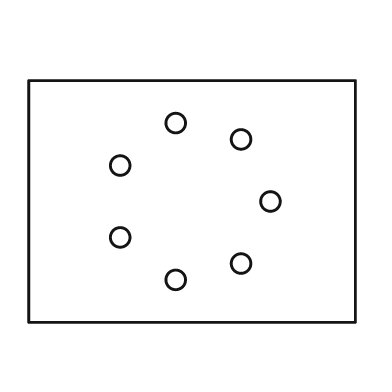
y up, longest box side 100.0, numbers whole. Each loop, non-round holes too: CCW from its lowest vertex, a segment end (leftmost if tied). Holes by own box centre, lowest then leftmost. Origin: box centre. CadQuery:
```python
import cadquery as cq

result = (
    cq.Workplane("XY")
    .moveTo(-50.0, -37.0)
    .lineTo(50.0, -37.0)
    .lineTo(50.0, 37.0)
    .lineTo(-50.0, 37.0)
    .close()
    .moveTo(-5.0, -24.0)
    .circle(3.0)
    .moveTo(15.0, -19.0)
    .circle(3.0)
    .moveTo(-22.0, -11.0)
    .circle(3.0)
    .moveTo(24.0, 0.0)
    .circle(3.0)
    .moveTo(-22.0, 11.0)
    .circle(3.0)
    .moveTo(15.0, 19.0)
    .circle(3.0)
    .moveTo(-5.0, 24.0)
    .circle(3.0)
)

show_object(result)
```